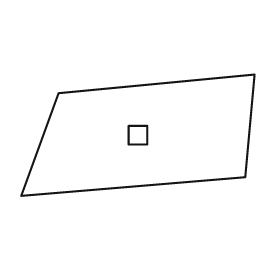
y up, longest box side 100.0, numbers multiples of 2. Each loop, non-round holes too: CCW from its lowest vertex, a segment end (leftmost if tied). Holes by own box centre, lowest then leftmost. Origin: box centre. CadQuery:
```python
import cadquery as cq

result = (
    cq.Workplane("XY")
    .moveTo(-50.0, -26.0)
    .lineTo(46.0, -18.0)
    .lineTo(50.0, 26.0)
    .lineTo(-34.0, 18.0)
    .close()
    .moveTo(-4.0, -4.0)
    .lineTo(4.0, -4.0)
    .lineTo(4.0, 4.0)
    .lineTo(-4.0, 4.0)
    .close()
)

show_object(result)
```